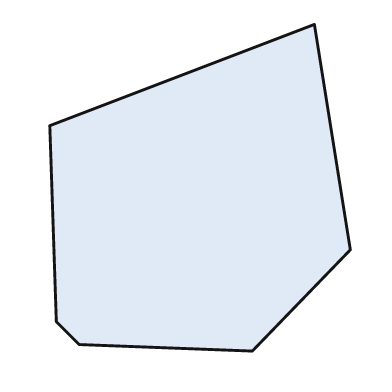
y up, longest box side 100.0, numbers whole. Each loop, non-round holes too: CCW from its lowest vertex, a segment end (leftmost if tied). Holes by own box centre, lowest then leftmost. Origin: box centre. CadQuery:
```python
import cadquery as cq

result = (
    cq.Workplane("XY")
    .moveTo(16.0, -50.0)
    .lineTo(46.0, -19.0)
    .lineTo(35.0, 50.0)
    .lineTo(-46.0, 19.0)
    .lineTo(-44.0, -41.0)
    .lineTo(-37.0, -48.0)
    .close()
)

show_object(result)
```